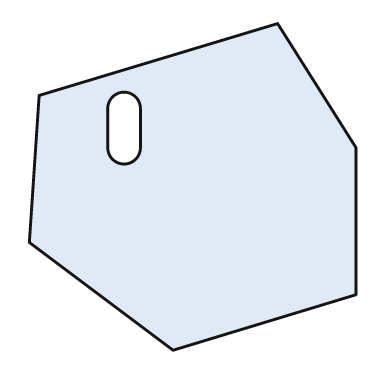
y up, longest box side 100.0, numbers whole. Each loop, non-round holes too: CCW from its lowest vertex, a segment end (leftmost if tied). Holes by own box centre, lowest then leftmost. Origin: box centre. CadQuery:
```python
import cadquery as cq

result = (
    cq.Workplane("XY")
    .moveTo(-6.0, -50.0)
    .lineTo(50.0, -33.0)
    .lineTo(50.0, 12.0)
    .lineTo(26.0, 50.0)
    .lineTo(-47.0, 28.0)
    .lineTo(-50.0, -17.0)
    .close()
    .moveTo(-26.0, 12.0)
    .threePointArc((-21.0, 7.0), (-16.0, 12.0))
    .lineTo(-16.0, 24.0)
    .threePointArc((-21.0, 29.0), (-26.0, 24.0))
    .close()
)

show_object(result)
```